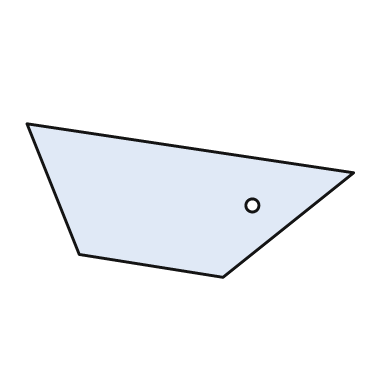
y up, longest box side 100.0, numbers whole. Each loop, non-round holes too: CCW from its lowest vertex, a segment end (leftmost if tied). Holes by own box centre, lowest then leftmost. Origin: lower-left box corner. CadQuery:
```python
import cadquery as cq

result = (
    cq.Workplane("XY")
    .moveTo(60.0, 0.0)
    .lineTo(100.0, 32.0)
    .lineTo(0.0, 47.0)
    .lineTo(16.0, 7.0)
    .close()
    .moveTo(69.0, 22.0)
    .circle(2.0)
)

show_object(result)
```